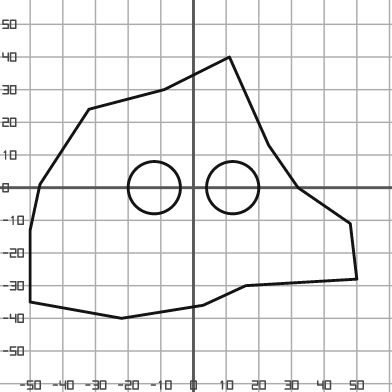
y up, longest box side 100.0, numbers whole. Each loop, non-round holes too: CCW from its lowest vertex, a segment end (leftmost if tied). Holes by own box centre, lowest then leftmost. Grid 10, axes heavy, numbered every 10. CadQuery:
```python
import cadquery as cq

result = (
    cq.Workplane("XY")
    .moveTo(-22.0, -40.0)
    .lineTo(3.0, -36.0)
    .lineTo(16.0, -30.0)
    .lineTo(50.0, -28.0)
    .lineTo(48.0, -11.0)
    .lineTo(32.0, 0.0)
    .lineTo(23.0, 13.0)
    .lineTo(11.0, 40.0)
    .lineTo(-9.0, 30.0)
    .lineTo(-32.0, 24.0)
    .lineTo(-47.0, 1.0)
    .lineTo(-50.0, -13.0)
    .lineTo(-50.0, -35.0)
    .close()
    .moveTo(-12.0, 0.0)
    .circle(8.0)
    .moveTo(12.0, 0.0)
    .circle(8.0)
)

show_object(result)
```